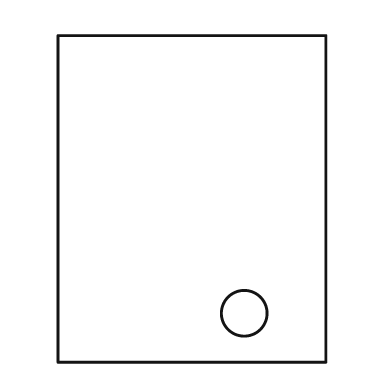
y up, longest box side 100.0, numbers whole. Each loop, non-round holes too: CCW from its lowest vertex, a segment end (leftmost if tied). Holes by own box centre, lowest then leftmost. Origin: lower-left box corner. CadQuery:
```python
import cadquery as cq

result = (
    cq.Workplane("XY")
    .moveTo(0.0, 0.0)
    .lineTo(82.0, 0.0)
    .lineTo(82.0, 100.0)
    .lineTo(0.0, 100.0)
    .close()
    .moveTo(57.0, 15.0)
    .circle(7.0)
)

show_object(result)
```